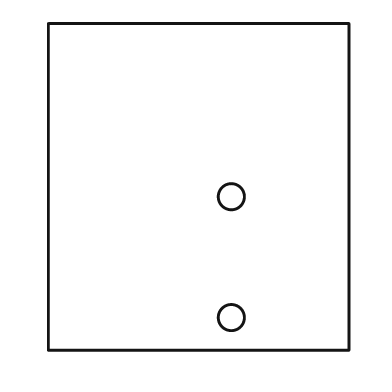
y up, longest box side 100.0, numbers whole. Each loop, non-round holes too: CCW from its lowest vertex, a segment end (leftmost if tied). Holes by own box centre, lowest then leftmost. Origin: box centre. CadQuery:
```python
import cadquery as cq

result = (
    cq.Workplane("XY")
    .moveTo(-46.0, -50.0)
    .lineTo(46.0, -50.0)
    .lineTo(46.0, 50.0)
    .lineTo(-46.0, 50.0)
    .close()
    .moveTo(10.0, -40.0)
    .circle(4.0)
    .moveTo(10.0, -3.0)
    .circle(4.0)
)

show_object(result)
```